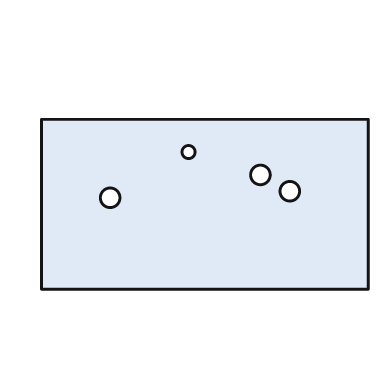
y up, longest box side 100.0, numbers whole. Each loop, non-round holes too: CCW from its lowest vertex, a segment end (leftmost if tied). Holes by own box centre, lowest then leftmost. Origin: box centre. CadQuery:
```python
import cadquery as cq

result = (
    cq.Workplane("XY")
    .moveTo(-50.0, -26.0)
    .lineTo(50.0, -26.0)
    .lineTo(50.0, 26.0)
    .lineTo(-50.0, 26.0)
    .close()
    .moveTo(-29.0, 2.0)
    .circle(3.0)
    .moveTo(26.0, 4.0)
    .circle(3.0)
    .moveTo(17.0, 9.0)
    .circle(3.0)
    .moveTo(-5.0, 16.0)
    .circle(2.0)
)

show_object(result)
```